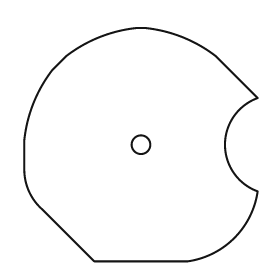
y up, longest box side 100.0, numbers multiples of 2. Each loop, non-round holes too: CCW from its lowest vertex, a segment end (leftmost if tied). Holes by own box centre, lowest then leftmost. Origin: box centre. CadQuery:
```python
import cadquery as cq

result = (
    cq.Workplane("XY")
    .moveTo(-20.0, -50.0)
    .lineTo(20.0, -50.0)
    .threePointArc((40.0, -40.0), (50.0, -20.0))
    .threePointArc((36.0, 0.0), (50.0, 20.0))
    .lineTo(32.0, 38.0)
    .threePointArc((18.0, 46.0), (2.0, 50.0))
    .lineTo(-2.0, 50.0)
    .threePointArc((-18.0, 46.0), (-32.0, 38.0))
    .lineTo(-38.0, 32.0)
    .threePointArc((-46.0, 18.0), (-50.0, 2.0))
    .lineTo(-50.0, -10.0)
    .threePointArc((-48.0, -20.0), (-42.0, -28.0))
    .close()
    .moveTo(0.0, 0.0)
    .circle(4.0)
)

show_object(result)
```